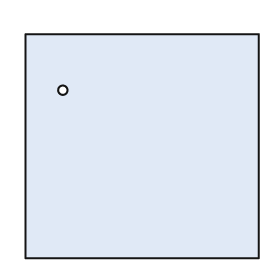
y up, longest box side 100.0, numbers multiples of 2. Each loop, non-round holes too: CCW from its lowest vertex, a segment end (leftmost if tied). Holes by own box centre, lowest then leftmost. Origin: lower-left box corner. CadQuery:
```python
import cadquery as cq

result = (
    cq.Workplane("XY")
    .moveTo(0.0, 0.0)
    .lineTo(100.0, 0.0)
    .lineTo(100.0, 96.0)
    .lineTo(0.0, 96.0)
    .close()
    .moveTo(16.0, 72.0)
    .circle(2.0)
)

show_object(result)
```